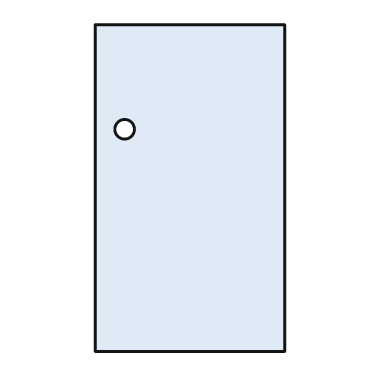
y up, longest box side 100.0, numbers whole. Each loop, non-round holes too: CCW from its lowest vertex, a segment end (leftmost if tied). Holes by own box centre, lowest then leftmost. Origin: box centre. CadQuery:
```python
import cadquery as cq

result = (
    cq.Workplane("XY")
    .moveTo(-29.0, -50.0)
    .lineTo(29.0, -50.0)
    .lineTo(29.0, 50.0)
    .lineTo(-29.0, 50.0)
    .close()
    .moveTo(-20.0, 18.0)
    .circle(3.0)
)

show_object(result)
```